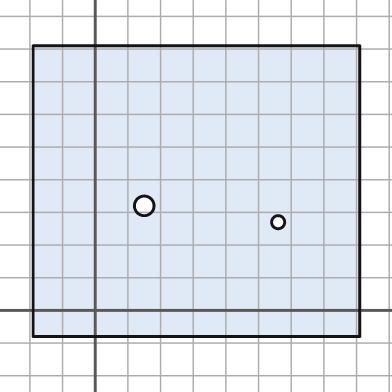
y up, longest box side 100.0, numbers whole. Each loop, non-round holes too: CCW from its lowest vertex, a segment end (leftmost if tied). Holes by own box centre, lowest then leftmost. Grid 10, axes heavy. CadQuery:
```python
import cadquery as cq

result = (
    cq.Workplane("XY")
    .moveTo(-19.0, -8.0)
    .lineTo(81.0, -8.0)
    .lineTo(81.0, 81.0)
    .lineTo(-19.0, 81.0)
    .close()
    .moveTo(56.0, 27.0)
    .circle(2.0)
    .moveTo(15.0, 32.0)
    .circle(3.0)
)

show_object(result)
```